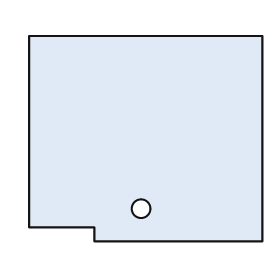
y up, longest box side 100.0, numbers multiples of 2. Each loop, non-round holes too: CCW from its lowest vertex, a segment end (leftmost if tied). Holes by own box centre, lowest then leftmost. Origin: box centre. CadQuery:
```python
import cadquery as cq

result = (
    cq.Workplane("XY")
    .moveTo(-22.0, -44.0)
    .lineTo(50.0, -44.0)
    .lineTo(50.0, 44.0)
    .lineTo(-50.0, 44.0)
    .lineTo(-50.0, -38.0)
    .lineTo(-22.0, -38.0)
    .close()
    .moveTo(-2.0, -30.0)
    .circle(4.0)
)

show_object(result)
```